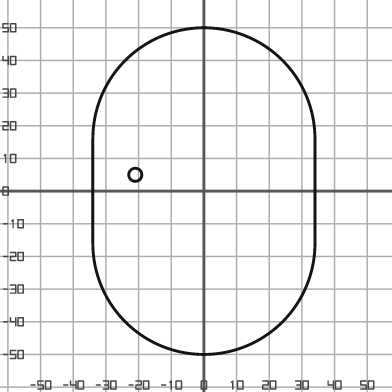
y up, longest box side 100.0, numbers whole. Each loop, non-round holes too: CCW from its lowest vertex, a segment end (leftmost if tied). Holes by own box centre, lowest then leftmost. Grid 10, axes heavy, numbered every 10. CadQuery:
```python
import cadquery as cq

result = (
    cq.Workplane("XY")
    .moveTo(-34.0, -16.0)
    .threePointArc((0.0, -50.0), (34.0, -16.0))
    .lineTo(34.0, 16.0)
    .threePointArc((0.0, 50.0), (-34.0, 16.0))
    .close()
    .moveTo(-21.0, 5.0)
    .circle(2.0)
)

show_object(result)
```